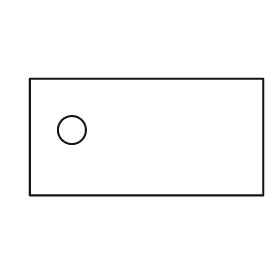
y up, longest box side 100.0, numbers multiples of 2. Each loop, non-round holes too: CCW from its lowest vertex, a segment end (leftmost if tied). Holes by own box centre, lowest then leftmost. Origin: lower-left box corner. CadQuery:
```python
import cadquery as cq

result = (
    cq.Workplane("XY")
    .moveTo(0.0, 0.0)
    .lineTo(100.0, 0.0)
    .lineTo(100.0, 50.0)
    .lineTo(0.0, 50.0)
    .close()
    .moveTo(18.0, 28.0)
    .circle(6.0)
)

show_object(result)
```